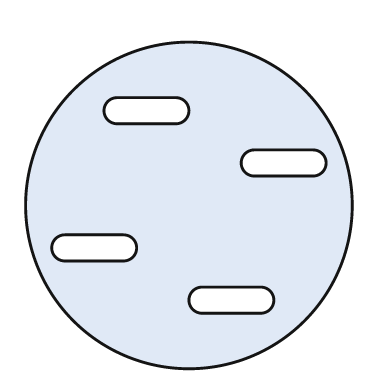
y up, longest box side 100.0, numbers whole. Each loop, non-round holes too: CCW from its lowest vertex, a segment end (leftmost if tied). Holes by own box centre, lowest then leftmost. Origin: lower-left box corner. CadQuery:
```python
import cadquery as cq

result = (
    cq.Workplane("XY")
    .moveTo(50.0, 50.0)
    .circle(50.0)
    .moveTo(54.0, 17.0)
    .lineTo(72.0, 17.0)
    .threePointArc((76.0, 21.0), (72.0, 25.0))
    .lineTo(54.0, 25.0)
    .threePointArc((50.0, 21.0), (54.0, 17.0))
    .close()
    .moveTo(12.0, 33.0)
    .lineTo(30.0, 33.0)
    .threePointArc((34.0, 37.0), (30.0, 41.0))
    .lineTo(12.0, 41.0)
    .threePointArc((8.0, 37.0), (12.0, 33.0))
    .close()
    .moveTo(70.0, 59.0)
    .lineTo(88.0, 59.0)
    .threePointArc((92.0, 63.0), (88.0, 67.0))
    .lineTo(70.0, 67.0)
    .threePointArc((66.0, 63.0), (70.0, 59.0))
    .close()
    .moveTo(28.0, 75.0)
    .lineTo(46.0, 75.0)
    .threePointArc((50.0, 79.0), (46.0, 83.0))
    .lineTo(28.0, 83.0)
    .threePointArc((24.0, 79.0), (28.0, 75.0))
    .close()
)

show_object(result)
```